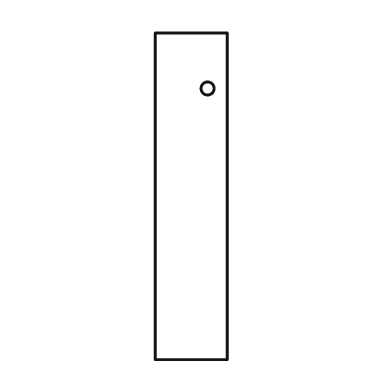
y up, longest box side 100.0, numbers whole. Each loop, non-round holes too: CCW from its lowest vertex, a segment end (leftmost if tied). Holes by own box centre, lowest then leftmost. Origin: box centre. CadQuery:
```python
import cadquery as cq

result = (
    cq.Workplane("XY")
    .moveTo(-11.0, -50.0)
    .lineTo(11.0, -50.0)
    .lineTo(11.0, 50.0)
    .lineTo(-11.0, 50.0)
    .close()
    .moveTo(5.0, 33.0)
    .circle(2.0)
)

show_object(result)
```